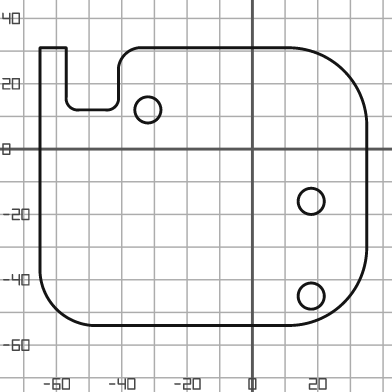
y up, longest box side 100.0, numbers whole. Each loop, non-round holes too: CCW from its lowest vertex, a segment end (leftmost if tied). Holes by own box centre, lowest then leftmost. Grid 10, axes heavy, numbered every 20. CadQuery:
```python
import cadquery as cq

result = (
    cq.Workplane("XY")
    .moveTo(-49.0, -54.0)
    .lineTo(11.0, -54.0)
    .threePointArc((28.0, -47.0), (35.0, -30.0))
    .lineTo(35.0, 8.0)
    .threePointArc((28.0, 24.0), (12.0, 31.0))
    .lineTo(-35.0, 31.0)
    .threePointArc((-39.0, 29.0), (-41.0, 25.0))
    .lineTo(-41.0, 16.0)
    .threePointArc((-42.0, 13.0), (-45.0, 12.0))
    .lineTo(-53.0, 12.0)
    .threePointArc((-56.0, 13.0), (-57.0, 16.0))
    .lineTo(-57.0, 31.0)
    .lineTo(-65.0, 31.0)
    .lineTo(-65.0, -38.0)
    .threePointArc((-60.0, -49.0), (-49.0, -54.0))
    .close()
    .moveTo(18.0, -45.0)
    .circle(4.0)
    .moveTo(18.0, -16.0)
    .circle(4.0)
    .moveTo(-32.0, 12.0)
    .circle(4.0)
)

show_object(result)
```